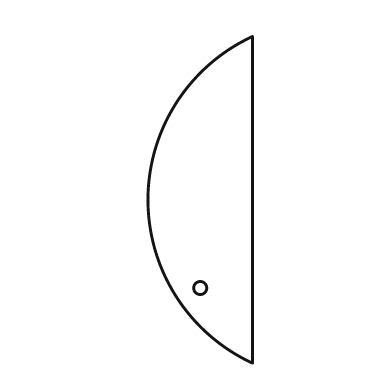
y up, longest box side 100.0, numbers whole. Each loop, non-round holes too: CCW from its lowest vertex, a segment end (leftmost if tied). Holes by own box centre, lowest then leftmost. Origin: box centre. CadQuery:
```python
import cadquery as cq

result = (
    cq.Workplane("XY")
    .moveTo(16.0, -50.0)
    .lineTo(16.0, 50.0)
    .threePointArc((-16.0, 0.0), (16.0, -50.0))
    .close()
    .moveTo(0.0, -27.0)
    .circle(2.0)
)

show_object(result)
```